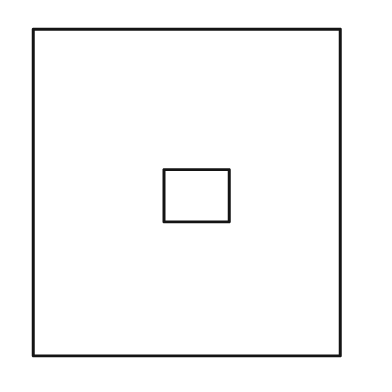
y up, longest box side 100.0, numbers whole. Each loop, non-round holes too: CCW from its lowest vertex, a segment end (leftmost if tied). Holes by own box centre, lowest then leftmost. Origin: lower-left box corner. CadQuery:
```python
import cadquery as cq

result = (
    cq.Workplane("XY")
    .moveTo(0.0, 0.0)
    .lineTo(94.0, 0.0)
    .lineTo(94.0, 100.0)
    .lineTo(0.0, 100.0)
    .close()
    .moveTo(40.0, 41.0)
    .lineTo(60.0, 41.0)
    .lineTo(60.0, 57.0)
    .lineTo(40.0, 57.0)
    .close()
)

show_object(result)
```